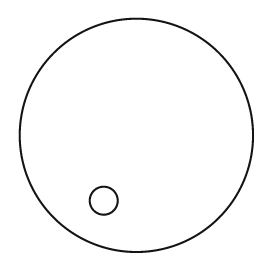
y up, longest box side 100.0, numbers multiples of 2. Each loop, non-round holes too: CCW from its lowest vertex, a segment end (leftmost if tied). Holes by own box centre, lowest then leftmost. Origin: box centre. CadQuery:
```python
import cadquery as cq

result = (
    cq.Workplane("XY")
    .moveTo(0.0, 0.0)
    .circle(50.0)
    .moveTo(-14.0, -28.0)
    .circle(6.0)
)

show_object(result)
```